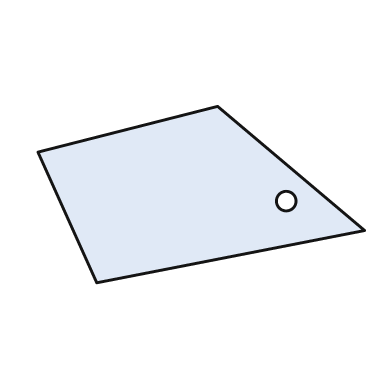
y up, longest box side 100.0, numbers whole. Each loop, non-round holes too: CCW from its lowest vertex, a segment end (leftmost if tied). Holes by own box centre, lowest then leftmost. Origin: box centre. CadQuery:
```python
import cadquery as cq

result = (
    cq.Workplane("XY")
    .moveTo(-32.0, -27.0)
    .lineTo(50.0, -11.0)
    .lineTo(5.0, 27.0)
    .lineTo(-50.0, 13.0)
    .close()
    .moveTo(26.0, -2.0)
    .circle(3.0)
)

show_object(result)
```